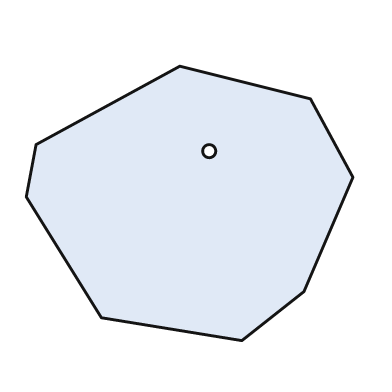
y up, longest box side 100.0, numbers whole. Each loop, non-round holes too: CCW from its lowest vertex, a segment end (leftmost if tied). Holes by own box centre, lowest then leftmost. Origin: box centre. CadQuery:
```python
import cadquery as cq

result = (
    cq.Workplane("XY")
    .moveTo(16.0, -42.0)
    .lineTo(35.0, -27.0)
    .lineTo(50.0, 8.0)
    .lineTo(37.0, 32.0)
    .lineTo(-3.0, 42.0)
    .lineTo(-47.0, 18.0)
    .lineTo(-50.0, 2.0)
    .lineTo(-27.0, -35.0)
    .close()
    .moveTo(6.0, 16.0)
    .circle(2.0)
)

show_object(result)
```